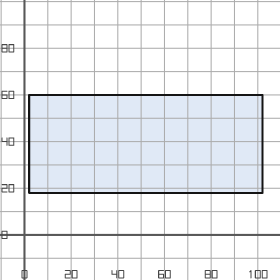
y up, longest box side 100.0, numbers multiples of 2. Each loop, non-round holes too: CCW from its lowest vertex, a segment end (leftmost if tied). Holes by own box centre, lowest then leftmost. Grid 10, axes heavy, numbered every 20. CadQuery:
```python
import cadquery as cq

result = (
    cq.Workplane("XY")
    .moveTo(2.0, 18.0)
    .lineTo(102.0, 18.0)
    .lineTo(102.0, 60.0)
    .lineTo(2.0, 60.0)
    .close()
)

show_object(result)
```